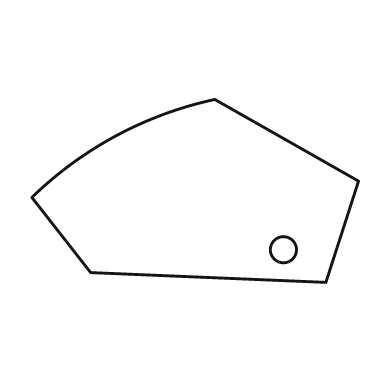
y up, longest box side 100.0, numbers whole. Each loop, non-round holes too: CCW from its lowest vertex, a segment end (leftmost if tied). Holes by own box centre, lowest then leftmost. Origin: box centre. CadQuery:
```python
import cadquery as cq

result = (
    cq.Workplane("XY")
    .moveTo(40.0, -28.0)
    .lineTo(50.0, 3.0)
    .lineTo(6.0, 28.0)
    .threePointArc((-24.0, 17.0), (-50.0, -2.0))
    .lineTo(-32.0, -25.0)
    .close()
    .moveTo(27.0, -18.0)
    .circle(4.0)
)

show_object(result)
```